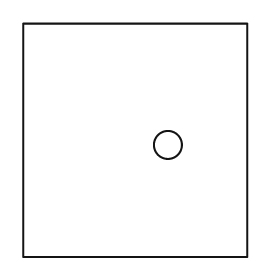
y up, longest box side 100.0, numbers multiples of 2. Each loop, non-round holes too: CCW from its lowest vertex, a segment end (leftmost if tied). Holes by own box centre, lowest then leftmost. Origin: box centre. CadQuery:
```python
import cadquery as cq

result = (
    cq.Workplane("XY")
    .moveTo(-48.0, -50.0)
    .lineTo(48.0, -50.0)
    .lineTo(48.0, 50.0)
    .lineTo(-48.0, 50.0)
    .close()
    .moveTo(14.0, -2.0)
    .circle(6.0)
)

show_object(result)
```